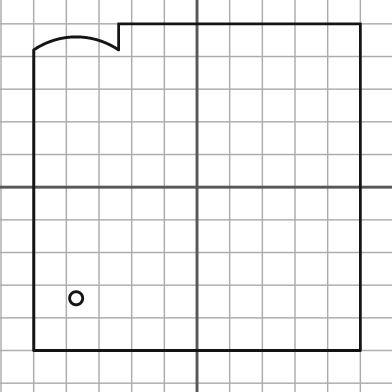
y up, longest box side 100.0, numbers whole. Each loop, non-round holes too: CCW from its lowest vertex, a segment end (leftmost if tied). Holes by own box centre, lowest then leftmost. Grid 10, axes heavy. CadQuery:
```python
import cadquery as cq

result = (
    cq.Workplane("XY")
    .moveTo(-50.0, -50.0)
    .lineTo(50.0, -50.0)
    .lineTo(50.0, 50.0)
    .lineTo(-24.0, 50.0)
    .lineTo(-24.0, 42.0)
    .threePointArc((-37.0, 46.0), (-50.0, 42.0))
    .close()
    .moveTo(-37.0, -34.0)
    .circle(2.0)
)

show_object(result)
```